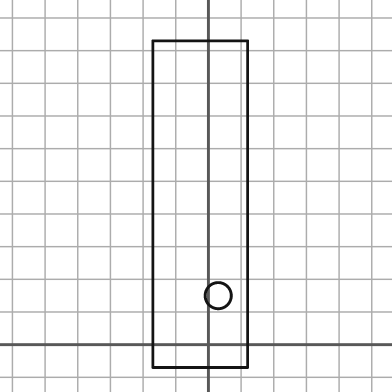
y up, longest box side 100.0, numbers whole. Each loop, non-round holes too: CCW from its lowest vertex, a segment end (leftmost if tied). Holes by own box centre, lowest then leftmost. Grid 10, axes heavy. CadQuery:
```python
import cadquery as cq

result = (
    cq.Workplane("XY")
    .moveTo(-17.0, -7.0)
    .lineTo(12.0, -7.0)
    .lineTo(12.0, 93.0)
    .lineTo(-17.0, 93.0)
    .close()
    .moveTo(3.0, 15.0)
    .circle(4.0)
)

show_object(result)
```